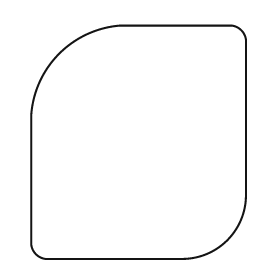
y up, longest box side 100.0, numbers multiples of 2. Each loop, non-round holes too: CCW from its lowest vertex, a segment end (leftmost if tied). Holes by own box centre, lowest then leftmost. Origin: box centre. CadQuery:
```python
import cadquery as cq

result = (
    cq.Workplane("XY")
    .moveTo(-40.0, -50.0)
    .lineTo(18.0, -50.0)
    .threePointArc((38.0, -42.0), (46.0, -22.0))
    .lineTo(46.0, 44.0)
    .threePointArc((44.0, 48.0), (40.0, 50.0))
    .lineTo(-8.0, 50.0)
    .threePointArc((-34.0, 38.0), (-46.0, 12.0))
    .lineTo(-46.0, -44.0)
    .threePointArc((-44.0, -48.0), (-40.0, -50.0))
    .close()
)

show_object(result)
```